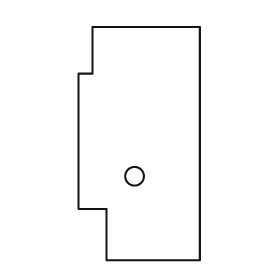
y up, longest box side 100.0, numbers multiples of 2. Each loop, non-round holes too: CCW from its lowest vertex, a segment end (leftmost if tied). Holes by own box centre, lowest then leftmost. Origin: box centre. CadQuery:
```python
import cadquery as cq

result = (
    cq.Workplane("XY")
    .moveTo(-14.0, -50.0)
    .lineTo(26.0, -50.0)
    .lineTo(26.0, 50.0)
    .lineTo(-20.0, 50.0)
    .lineTo(-20.0, 30.0)
    .lineTo(-26.0, 30.0)
    .lineTo(-26.0, -28.0)
    .lineTo(-14.0, -28.0)
    .close()
    .moveTo(-2.0, -14.0)
    .circle(4.0)
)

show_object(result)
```